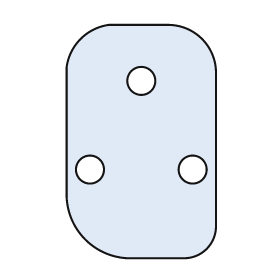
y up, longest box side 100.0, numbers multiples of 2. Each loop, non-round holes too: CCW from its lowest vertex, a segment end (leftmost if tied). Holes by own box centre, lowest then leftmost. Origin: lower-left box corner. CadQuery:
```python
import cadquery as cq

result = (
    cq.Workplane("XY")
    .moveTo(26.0, 0.0)
    .lineTo(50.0, 0.0)
    .threePointArc((60.0, 4.0), (64.0, 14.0))
    .lineTo(64.0, 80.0)
    .threePointArc((58.0, 94.0), (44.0, 100.0))
    .lineTo(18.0, 100.0)
    .threePointArc((6.0, 94.0), (0.0, 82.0))
    .lineTo(0.0, 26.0)
    .threePointArc((8.0, 8.0), (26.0, 0.0))
    .close()
    .moveTo(10.0, 38.0)
    .circle(6.0)
    .moveTo(54.0, 38.0)
    .circle(6.0)
    .moveTo(32.0, 76.0)
    .circle(6.0)
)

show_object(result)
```